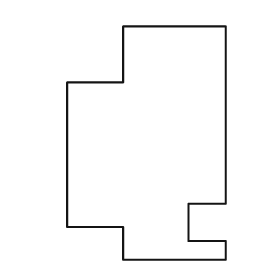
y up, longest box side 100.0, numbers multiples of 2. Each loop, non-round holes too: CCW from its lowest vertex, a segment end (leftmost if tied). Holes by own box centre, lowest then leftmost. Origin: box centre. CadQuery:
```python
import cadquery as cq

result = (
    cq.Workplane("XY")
    .moveTo(-10.0, -50.0)
    .lineTo(34.0, -50.0)
    .lineTo(34.0, -42.0)
    .lineTo(18.0, -42.0)
    .lineTo(18.0, -26.0)
    .lineTo(34.0, -26.0)
    .lineTo(34.0, 50.0)
    .lineTo(-10.0, 50.0)
    .lineTo(-10.0, 26.0)
    .lineTo(-34.0, 26.0)
    .lineTo(-34.0, -36.0)
    .lineTo(-10.0, -36.0)
    .close()
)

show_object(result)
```